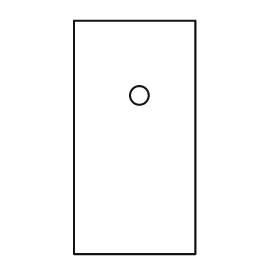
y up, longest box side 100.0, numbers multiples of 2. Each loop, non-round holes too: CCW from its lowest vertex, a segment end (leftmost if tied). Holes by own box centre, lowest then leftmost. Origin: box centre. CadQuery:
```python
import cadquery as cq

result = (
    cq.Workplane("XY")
    .moveTo(-26.0, -50.0)
    .lineTo(26.0, -50.0)
    .lineTo(26.0, 50.0)
    .lineTo(-26.0, 50.0)
    .close()
    .moveTo(2.0, 18.0)
    .circle(4.0)
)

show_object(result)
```